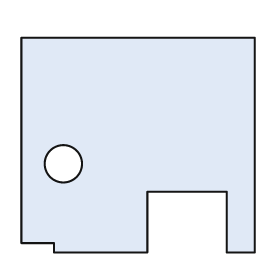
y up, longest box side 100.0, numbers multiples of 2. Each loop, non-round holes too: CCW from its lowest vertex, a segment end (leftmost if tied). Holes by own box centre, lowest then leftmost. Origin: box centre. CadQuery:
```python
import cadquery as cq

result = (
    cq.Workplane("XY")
    .moveTo(-36.0, -46.0)
    .lineTo(4.0, -46.0)
    .lineTo(4.0, -20.0)
    .lineTo(38.0, -20.0)
    .lineTo(38.0, -46.0)
    .lineTo(50.0, -46.0)
    .lineTo(50.0, 46.0)
    .lineTo(-50.0, 46.0)
    .lineTo(-50.0, -42.0)
    .lineTo(-36.0, -42.0)
    .close()
    .moveTo(-32.0, -8.0)
    .circle(8.0)
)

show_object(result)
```